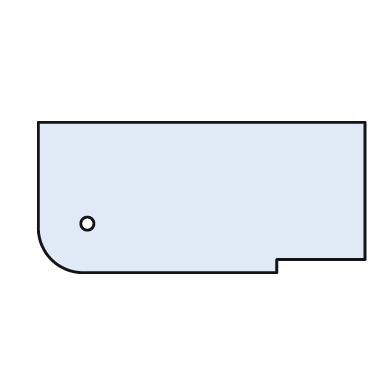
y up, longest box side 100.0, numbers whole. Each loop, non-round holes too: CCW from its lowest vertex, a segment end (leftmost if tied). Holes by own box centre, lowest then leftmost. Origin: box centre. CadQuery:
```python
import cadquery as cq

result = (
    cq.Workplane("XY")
    .moveTo(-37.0, -23.0)
    .lineTo(23.0, -23.0)
    .lineTo(23.0, -19.0)
    .lineTo(50.0, -19.0)
    .lineTo(50.0, 23.0)
    .lineTo(-50.0, 23.0)
    .lineTo(-50.0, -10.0)
    .threePointArc((-46.0, -19.0), (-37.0, -23.0))
    .close()
    .moveTo(-35.0, -8.0)
    .circle(2.0)
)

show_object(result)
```